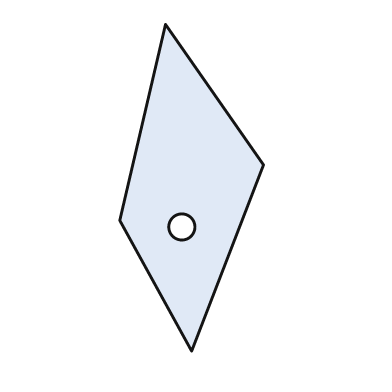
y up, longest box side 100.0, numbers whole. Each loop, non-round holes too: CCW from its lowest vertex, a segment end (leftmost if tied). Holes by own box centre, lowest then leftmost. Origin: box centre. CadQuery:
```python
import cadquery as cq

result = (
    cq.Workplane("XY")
    .moveTo(0.0, -50.0)
    .lineTo(22.0, 7.0)
    .lineTo(-8.0, 50.0)
    .lineTo(-22.0, -10.0)
    .close()
    .moveTo(-3.0, -12.0)
    .circle(4.0)
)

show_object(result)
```